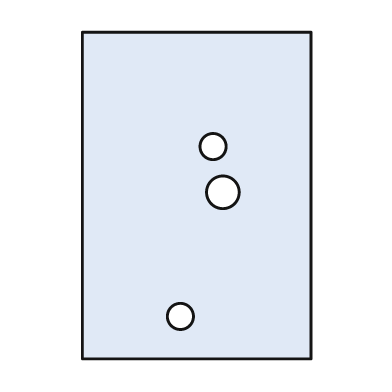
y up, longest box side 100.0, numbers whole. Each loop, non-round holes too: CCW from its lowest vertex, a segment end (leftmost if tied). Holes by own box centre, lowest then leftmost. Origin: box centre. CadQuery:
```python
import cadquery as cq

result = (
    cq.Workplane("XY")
    .moveTo(-35.0, -50.0)
    .lineTo(35.0, -50.0)
    .lineTo(35.0, 50.0)
    .lineTo(-35.0, 50.0)
    .close()
    .moveTo(-5.0, -37.0)
    .circle(4.0)
    .moveTo(8.0, 1.0)
    .circle(5.0)
    .moveTo(5.0, 15.0)
    .circle(4.0)
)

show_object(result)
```